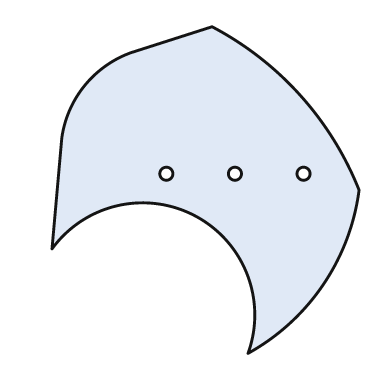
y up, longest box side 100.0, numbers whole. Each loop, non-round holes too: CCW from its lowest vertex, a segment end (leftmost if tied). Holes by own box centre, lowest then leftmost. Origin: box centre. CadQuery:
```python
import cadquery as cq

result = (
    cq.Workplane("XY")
    .moveTo(13.0, -50.0)
    .threePointArc((36.0, -29.0), (47.0, 0.0))
    .threePointArc((29.0, 29.0), (2.0, 50.0))
    .lineTo(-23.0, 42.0)
    .threePointArc((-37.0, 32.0), (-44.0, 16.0))
    .lineTo(-47.0, -18.0)
    .threePointArc((-3.0, -8.0), (13.0, -50.0))
    .close()
    .moveTo(-12.0, 5.0)
    .circle(2.0)
    .moveTo(9.0, 5.0)
    .circle(2.0)
    .moveTo(30.0, 5.0)
    .circle(2.0)
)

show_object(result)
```